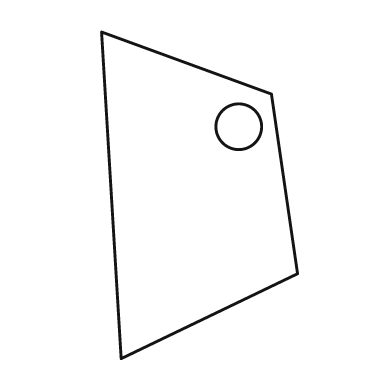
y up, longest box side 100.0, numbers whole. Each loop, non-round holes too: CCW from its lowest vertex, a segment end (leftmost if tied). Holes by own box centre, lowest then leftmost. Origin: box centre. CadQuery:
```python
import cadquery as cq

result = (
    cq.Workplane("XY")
    .moveTo(-24.0, -50.0)
    .lineTo(30.0, -24.0)
    .lineTo(22.0, 31.0)
    .lineTo(-30.0, 50.0)
    .close()
    .moveTo(12.0, 21.0)
    .circle(7.0)
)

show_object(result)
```